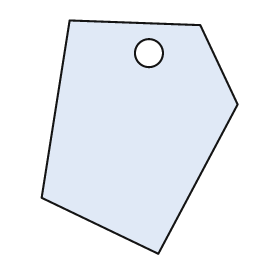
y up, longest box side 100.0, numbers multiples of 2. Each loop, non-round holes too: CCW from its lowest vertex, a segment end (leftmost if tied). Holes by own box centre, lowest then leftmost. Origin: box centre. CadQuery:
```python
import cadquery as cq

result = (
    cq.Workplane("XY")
    .moveTo(8.0, -50.0)
    .lineTo(42.0, 14.0)
    .lineTo(26.0, 48.0)
    .lineTo(-30.0, 50.0)
    .lineTo(-42.0, -26.0)
    .close()
    .moveTo(4.0, 36.0)
    .circle(6.0)
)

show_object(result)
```